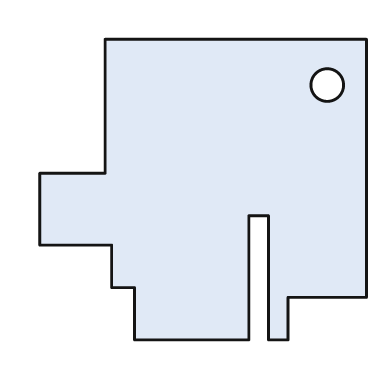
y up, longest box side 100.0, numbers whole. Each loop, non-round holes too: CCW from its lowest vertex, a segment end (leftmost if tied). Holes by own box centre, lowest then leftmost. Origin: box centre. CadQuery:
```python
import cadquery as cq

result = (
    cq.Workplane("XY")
    .moveTo(-21.0, -46.0)
    .lineTo(14.0, -46.0)
    .lineTo(14.0, -8.0)
    .lineTo(20.0, -8.0)
    .lineTo(20.0, -46.0)
    .lineTo(26.0, -46.0)
    .lineTo(26.0, -33.0)
    .lineTo(50.0, -33.0)
    .lineTo(50.0, 46.0)
    .lineTo(-30.0, 46.0)
    .lineTo(-30.0, 5.0)
    .lineTo(-50.0, 5.0)
    .lineTo(-50.0, -17.0)
    .lineTo(-28.0, -17.0)
    .lineTo(-28.0, -30.0)
    .lineTo(-21.0, -30.0)
    .close()
    .moveTo(38.0, 32.0)
    .circle(5.0)
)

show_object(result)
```